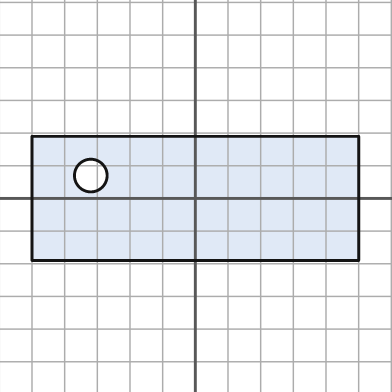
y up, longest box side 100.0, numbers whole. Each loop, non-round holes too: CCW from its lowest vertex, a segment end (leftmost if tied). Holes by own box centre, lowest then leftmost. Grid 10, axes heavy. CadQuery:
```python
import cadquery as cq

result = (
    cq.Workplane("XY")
    .moveTo(-50.0, -19.0)
    .lineTo(50.0, -19.0)
    .lineTo(50.0, 19.0)
    .lineTo(-50.0, 19.0)
    .close()
    .moveTo(-32.0, 7.0)
    .circle(5.0)
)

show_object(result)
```